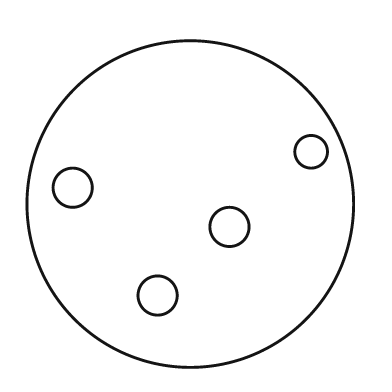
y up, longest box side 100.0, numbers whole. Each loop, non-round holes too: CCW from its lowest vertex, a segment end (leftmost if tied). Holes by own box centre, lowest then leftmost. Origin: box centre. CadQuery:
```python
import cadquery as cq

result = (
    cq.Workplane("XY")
    .moveTo(0.0, 0.0)
    .circle(50.0)
    .moveTo(-10.0, -28.0)
    .circle(6.0)
    .moveTo(12.0, -7.0)
    .circle(6.0)
    .moveTo(-36.0, 5.0)
    .circle(6.0)
    .moveTo(37.0, 16.0)
    .circle(5.0)
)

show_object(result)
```